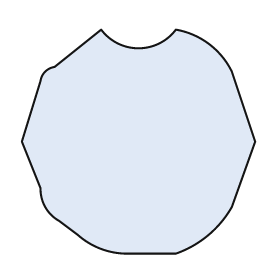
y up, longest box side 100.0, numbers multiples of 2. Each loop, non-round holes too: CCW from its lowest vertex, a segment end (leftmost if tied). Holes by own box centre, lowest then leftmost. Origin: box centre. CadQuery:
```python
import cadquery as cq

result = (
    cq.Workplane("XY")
    .moveTo(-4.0, -48.0)
    .lineTo(16.0, -48.0)
    .threePointArc((30.0, -40.0), (40.0, -28.0))
    .lineTo(50.0, 0.0)
    .lineTo(40.0, 30.0)
    .threePointArc((30.0, 42.0), (16.0, 48.0))
    .threePointArc((0.0, 40.0), (-16.0, 48.0))
    .lineTo(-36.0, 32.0)
    .threePointArc((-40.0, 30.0), (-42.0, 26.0))
    .lineTo(-50.0, 0.0)
    .lineTo(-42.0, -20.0)
    .threePointArc((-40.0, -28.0), (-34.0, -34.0))
    .lineTo(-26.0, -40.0)
    .threePointArc((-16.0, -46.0), (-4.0, -48.0))
    .close()
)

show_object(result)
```